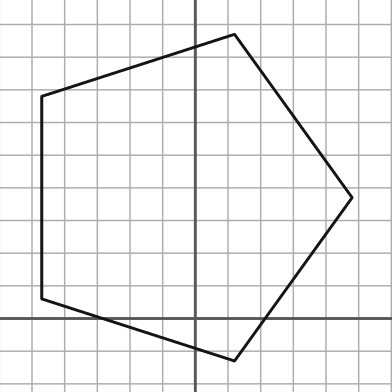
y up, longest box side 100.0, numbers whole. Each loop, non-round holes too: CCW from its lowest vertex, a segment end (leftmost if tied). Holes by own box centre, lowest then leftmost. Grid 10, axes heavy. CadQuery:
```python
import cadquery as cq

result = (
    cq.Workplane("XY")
    .moveTo(12.0, -13.0)
    .lineTo(48.0, 37.0)
    .lineTo(12.0, 87.0)
    .lineTo(-47.0, 68.0)
    .lineTo(-47.0, 6.0)
    .close()
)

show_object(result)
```